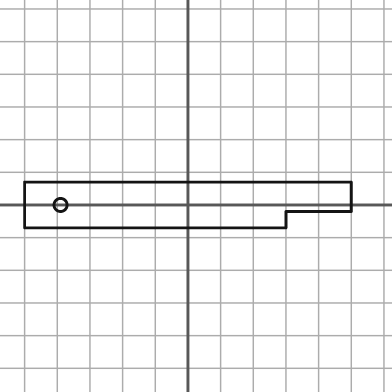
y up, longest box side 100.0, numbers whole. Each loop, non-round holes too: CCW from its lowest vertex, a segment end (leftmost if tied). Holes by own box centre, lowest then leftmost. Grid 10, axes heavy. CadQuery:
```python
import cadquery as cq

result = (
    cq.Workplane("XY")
    .moveTo(-50.0, -7.0)
    .lineTo(30.0, -7.0)
    .lineTo(30.0, -2.0)
    .lineTo(50.0, -2.0)
    .lineTo(50.0, 7.0)
    .lineTo(-50.0, 7.0)
    .close()
    .moveTo(-39.0, 0.0)
    .circle(2.0)
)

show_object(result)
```